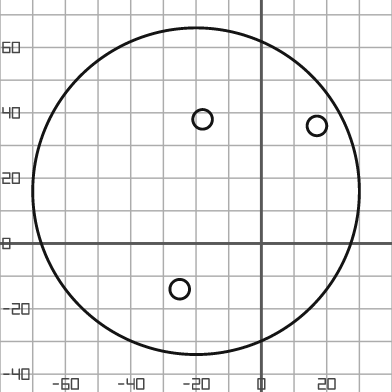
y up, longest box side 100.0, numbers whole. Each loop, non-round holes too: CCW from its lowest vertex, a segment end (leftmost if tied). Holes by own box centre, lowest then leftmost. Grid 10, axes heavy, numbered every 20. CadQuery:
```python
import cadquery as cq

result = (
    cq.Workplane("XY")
    .moveTo(-20.0, 16.0)
    .circle(50.0)
    .moveTo(-25.0, -14.0)
    .circle(3.0)
    .moveTo(17.0, 36.0)
    .circle(3.0)
    .moveTo(-18.0, 38.0)
    .circle(3.0)
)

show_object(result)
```